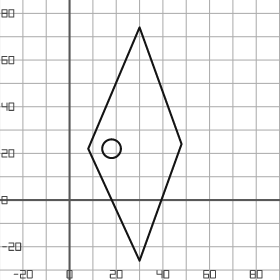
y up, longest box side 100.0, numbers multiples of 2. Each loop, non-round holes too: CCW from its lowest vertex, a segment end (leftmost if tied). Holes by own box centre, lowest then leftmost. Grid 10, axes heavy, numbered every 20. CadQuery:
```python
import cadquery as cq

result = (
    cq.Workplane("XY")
    .moveTo(30.0, -26.0)
    .lineTo(48.0, 24.0)
    .lineTo(30.0, 74.0)
    .lineTo(8.0, 22.0)
    .close()
    .moveTo(18.0, 22.0)
    .circle(4.0)
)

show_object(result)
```